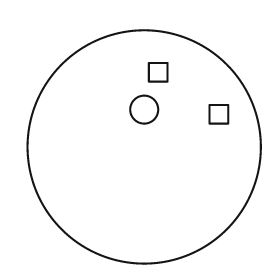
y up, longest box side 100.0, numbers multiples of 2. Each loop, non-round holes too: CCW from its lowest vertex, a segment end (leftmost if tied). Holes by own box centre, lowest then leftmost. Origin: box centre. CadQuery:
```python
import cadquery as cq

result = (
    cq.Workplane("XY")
    .moveTo(0.0, 0.0)
    .circle(50.0)
    .moveTo(28.0, 10.0)
    .lineTo(36.0, 10.0)
    .lineTo(36.0, 18.0)
    .lineTo(28.0, 18.0)
    .close()
    .moveTo(0.0, 16.0)
    .circle(6.0)
    .moveTo(2.0, 28.0)
    .lineTo(10.0, 28.0)
    .lineTo(10.0, 36.0)
    .lineTo(2.0, 36.0)
    .close()
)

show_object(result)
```